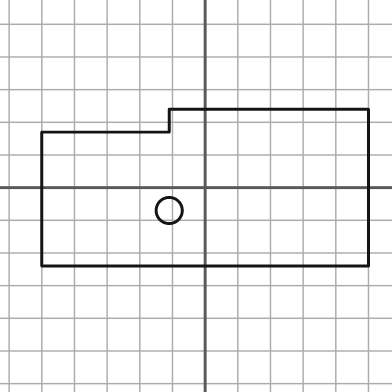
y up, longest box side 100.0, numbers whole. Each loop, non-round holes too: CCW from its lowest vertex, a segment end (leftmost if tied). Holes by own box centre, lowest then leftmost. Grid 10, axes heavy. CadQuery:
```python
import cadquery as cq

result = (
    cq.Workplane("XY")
    .moveTo(-50.0, -24.0)
    .lineTo(50.0, -24.0)
    .lineTo(50.0, 24.0)
    .lineTo(-11.0, 24.0)
    .lineTo(-11.0, 17.0)
    .lineTo(-50.0, 17.0)
    .close()
    .moveTo(-11.0, -7.0)
    .circle(4.0)
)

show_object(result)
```